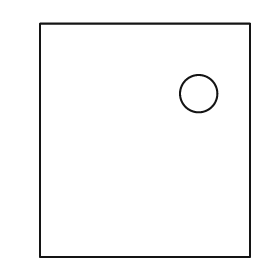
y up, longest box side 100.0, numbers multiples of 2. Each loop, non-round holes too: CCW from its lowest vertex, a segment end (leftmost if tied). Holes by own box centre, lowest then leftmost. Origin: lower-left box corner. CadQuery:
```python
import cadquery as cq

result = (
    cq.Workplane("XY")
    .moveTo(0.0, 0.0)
    .lineTo(90.0, 0.0)
    .lineTo(90.0, 100.0)
    .lineTo(0.0, 100.0)
    .close()
    .moveTo(68.0, 70.0)
    .circle(8.0)
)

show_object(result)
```